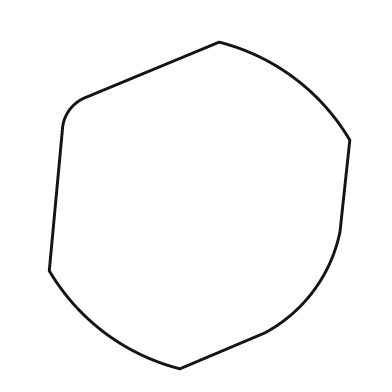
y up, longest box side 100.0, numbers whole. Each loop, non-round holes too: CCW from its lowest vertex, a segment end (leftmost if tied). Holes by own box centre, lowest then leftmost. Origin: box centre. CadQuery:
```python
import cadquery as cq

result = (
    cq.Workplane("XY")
    .moveTo(-6.0, -50.0)
    .lineTo(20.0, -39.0)
    .threePointArc((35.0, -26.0), (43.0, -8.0))
    .lineTo(46.0, 20.0)
    .threePointArc((29.0, 39.0), (6.0, 50.0))
    .lineTo(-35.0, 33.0)
    .threePointArc((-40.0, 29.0), (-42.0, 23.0))
    .lineTo(-46.0, -20.0)
    .threePointArc((-29.0, -39.0), (-6.0, -50.0))
    .close()
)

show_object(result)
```